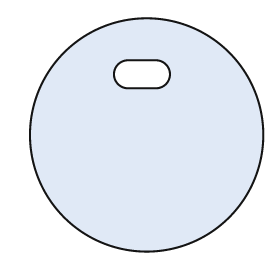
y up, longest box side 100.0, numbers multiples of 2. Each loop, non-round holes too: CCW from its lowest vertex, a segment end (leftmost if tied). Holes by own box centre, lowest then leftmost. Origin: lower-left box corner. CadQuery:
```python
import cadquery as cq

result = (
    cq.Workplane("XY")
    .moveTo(50.0, 50.0)
    .circle(50.0)
    .moveTo(42.0, 70.0)
    .lineTo(54.0, 70.0)
    .threePointArc((60.0, 76.0), (54.0, 82.0))
    .lineTo(42.0, 82.0)
    .threePointArc((36.0, 76.0), (42.0, 70.0))
    .close()
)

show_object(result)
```